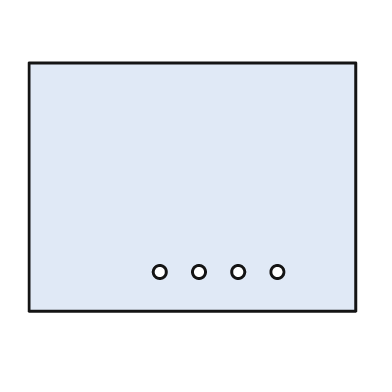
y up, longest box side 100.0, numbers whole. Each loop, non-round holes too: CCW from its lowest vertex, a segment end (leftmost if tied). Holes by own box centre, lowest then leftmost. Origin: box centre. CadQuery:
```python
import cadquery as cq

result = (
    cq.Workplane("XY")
    .moveTo(-50.0, -38.0)
    .lineTo(50.0, -38.0)
    .lineTo(50.0, 38.0)
    .lineTo(-50.0, 38.0)
    .close()
    .moveTo(-10.0, -26.0)
    .circle(2.0)
    .moveTo(2.0, -26.0)
    .circle(2.0)
    .moveTo(14.0, -26.0)
    .circle(2.0)
    .moveTo(26.0, -26.0)
    .circle(2.0)
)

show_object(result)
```